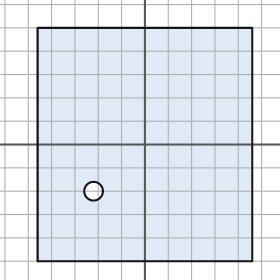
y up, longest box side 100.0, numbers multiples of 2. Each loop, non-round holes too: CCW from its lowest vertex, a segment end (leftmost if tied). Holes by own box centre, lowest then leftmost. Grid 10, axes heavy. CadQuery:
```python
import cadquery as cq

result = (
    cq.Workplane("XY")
    .moveTo(-46.0, -50.0)
    .lineTo(46.0, -50.0)
    .lineTo(46.0, 50.0)
    .lineTo(-46.0, 50.0)
    .close()
    .moveTo(-22.0, -20.0)
    .circle(4.0)
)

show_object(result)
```